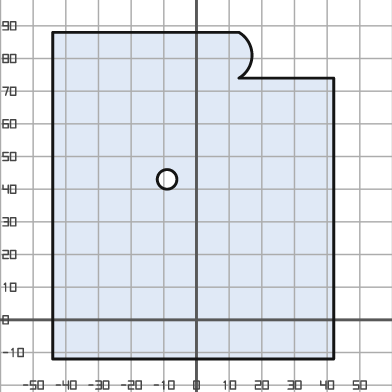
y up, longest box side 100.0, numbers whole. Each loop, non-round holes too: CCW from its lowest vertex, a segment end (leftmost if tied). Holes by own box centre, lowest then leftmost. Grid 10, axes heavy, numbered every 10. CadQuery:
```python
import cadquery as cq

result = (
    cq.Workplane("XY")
    .moveTo(-44.0, -12.0)
    .lineTo(42.0, -12.0)
    .lineTo(42.0, 74.0)
    .lineTo(13.0, 74.0)
    .threePointArc((17.0, 81.0), (13.0, 88.0))
    .lineTo(-44.0, 88.0)
    .close()
    .moveTo(-9.0, 43.0)
    .circle(3.0)
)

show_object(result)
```